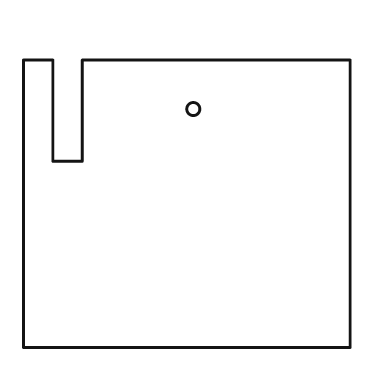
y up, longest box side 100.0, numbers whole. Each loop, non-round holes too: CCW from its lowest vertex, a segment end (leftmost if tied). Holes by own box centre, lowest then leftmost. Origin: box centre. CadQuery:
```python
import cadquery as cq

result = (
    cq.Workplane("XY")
    .moveTo(-50.0, -44.0)
    .lineTo(50.0, -44.0)
    .lineTo(50.0, 44.0)
    .lineTo(-32.0, 44.0)
    .lineTo(-32.0, 13.0)
    .lineTo(-41.0, 13.0)
    .lineTo(-41.0, 44.0)
    .lineTo(-50.0, 44.0)
    .close()
    .moveTo(2.0, 29.0)
    .circle(2.0)
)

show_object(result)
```